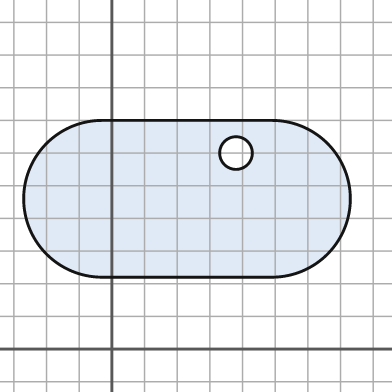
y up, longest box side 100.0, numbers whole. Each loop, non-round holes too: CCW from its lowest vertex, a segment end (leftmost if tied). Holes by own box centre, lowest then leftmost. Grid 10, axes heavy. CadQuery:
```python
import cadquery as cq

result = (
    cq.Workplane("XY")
    .moveTo(-3.0, 22.0)
    .lineTo(49.0, 22.0)
    .threePointArc((73.0, 46.0), (49.0, 70.0))
    .lineTo(-3.0, 70.0)
    .threePointArc((-27.0, 46.0), (-3.0, 22.0))
    .close()
    .moveTo(38.0, 60.0)
    .circle(5.0)
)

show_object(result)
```